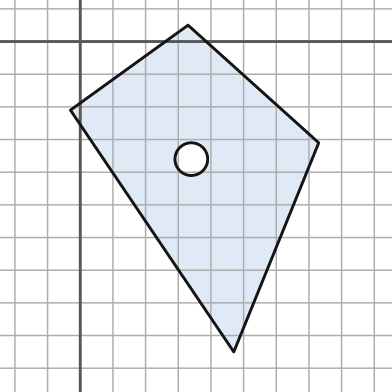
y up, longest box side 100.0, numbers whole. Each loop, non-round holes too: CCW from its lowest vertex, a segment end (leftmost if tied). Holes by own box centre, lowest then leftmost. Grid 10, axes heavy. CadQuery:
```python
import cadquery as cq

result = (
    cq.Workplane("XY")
    .moveTo(47.0, -95.0)
    .lineTo(73.0, -31.0)
    .lineTo(33.0, 5.0)
    .lineTo(-3.0, -21.0)
    .close()
    .moveTo(34.0, -36.0)
    .circle(5.0)
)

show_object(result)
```